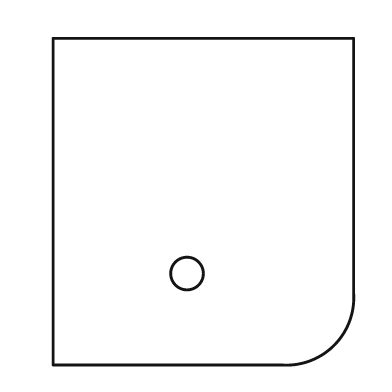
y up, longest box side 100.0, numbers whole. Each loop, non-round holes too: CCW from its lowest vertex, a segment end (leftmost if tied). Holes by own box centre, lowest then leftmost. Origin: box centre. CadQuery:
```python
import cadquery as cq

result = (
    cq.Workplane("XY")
    .moveTo(-46.0, -50.0)
    .lineTo(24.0, -50.0)
    .threePointArc((40.0, -44.0), (46.0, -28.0))
    .lineTo(46.0, 50.0)
    .lineTo(-46.0, 50.0)
    .close()
    .moveTo(-5.0, -22.0)
    .circle(5.0)
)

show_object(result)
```